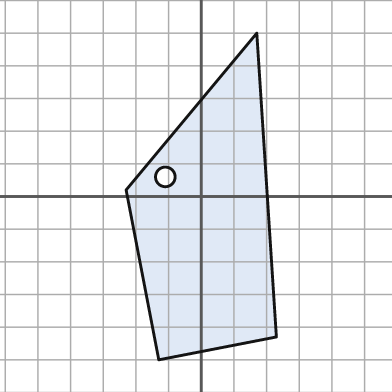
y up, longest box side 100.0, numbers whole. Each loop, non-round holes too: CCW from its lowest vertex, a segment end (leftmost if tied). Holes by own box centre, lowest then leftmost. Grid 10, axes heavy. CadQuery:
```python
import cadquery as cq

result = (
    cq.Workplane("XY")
    .moveTo(-13.0, -50.0)
    .lineTo(23.0, -43.0)
    .lineTo(17.0, 50.0)
    .lineTo(-23.0, 2.0)
    .close()
    .moveTo(-11.0, 6.0)
    .circle(3.0)
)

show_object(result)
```